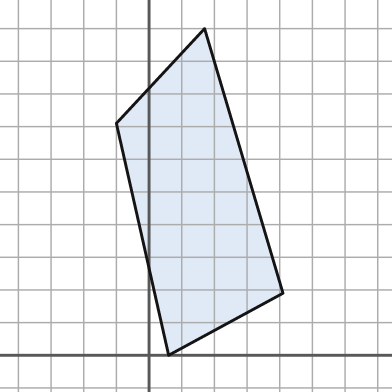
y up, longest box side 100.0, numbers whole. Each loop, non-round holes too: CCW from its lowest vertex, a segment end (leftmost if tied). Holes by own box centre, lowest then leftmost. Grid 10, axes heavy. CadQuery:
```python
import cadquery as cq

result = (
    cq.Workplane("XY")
    .moveTo(6.0, 0.0)
    .lineTo(41.0, 19.0)
    .lineTo(17.0, 100.0)
    .lineTo(-10.0, 71.0)
    .close()
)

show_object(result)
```